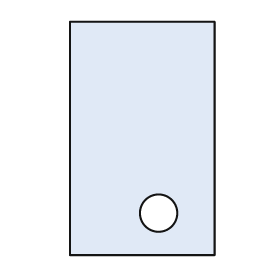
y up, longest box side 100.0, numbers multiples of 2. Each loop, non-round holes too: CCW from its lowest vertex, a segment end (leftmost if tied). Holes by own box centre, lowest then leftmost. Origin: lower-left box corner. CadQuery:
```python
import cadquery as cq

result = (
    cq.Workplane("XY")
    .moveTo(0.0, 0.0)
    .lineTo(62.0, 0.0)
    .lineTo(62.0, 100.0)
    .lineTo(0.0, 100.0)
    .close()
    .moveTo(38.0, 18.0)
    .circle(8.0)
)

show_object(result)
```